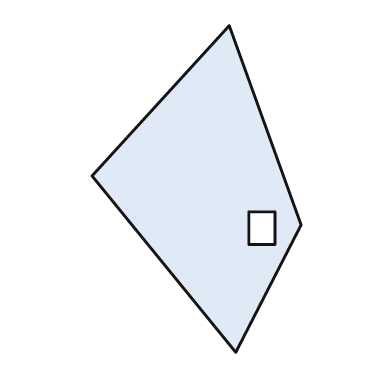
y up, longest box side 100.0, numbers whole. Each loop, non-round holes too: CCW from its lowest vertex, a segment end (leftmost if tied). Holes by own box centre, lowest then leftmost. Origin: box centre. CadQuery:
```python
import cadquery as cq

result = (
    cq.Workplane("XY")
    .moveTo(12.0, -50.0)
    .lineTo(32.0, -11.0)
    .lineTo(10.0, 50.0)
    .lineTo(-32.0, 4.0)
    .close()
    .moveTo(16.0, -17.0)
    .lineTo(24.0, -17.0)
    .lineTo(24.0, -7.0)
    .lineTo(16.0, -7.0)
    .close()
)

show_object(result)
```